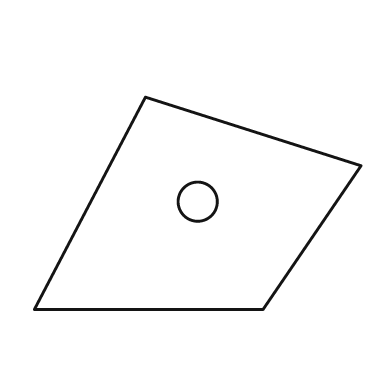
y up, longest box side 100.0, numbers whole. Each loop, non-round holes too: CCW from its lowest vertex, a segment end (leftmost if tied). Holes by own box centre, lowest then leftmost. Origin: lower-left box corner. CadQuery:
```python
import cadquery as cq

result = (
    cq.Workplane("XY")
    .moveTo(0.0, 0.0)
    .lineTo(70.0, 0.0)
    .lineTo(100.0, 44.0)
    .lineTo(34.0, 65.0)
    .close()
    .moveTo(50.0, 33.0)
    .circle(6.0)
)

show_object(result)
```